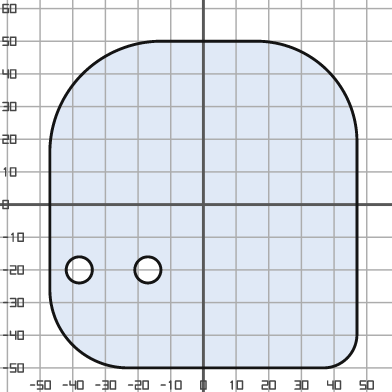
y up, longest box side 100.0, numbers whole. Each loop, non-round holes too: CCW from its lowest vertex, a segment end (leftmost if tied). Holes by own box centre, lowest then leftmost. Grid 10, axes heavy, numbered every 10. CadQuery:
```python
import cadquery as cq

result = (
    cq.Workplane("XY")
    .moveTo(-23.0, -50.0)
    .lineTo(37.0, -50.0)
    .threePointArc((44.0, -47.0), (47.0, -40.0))
    .lineTo(47.0, 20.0)
    .threePointArc((38.0, 41.0), (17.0, 50.0))
    .lineTo(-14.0, 50.0)
    .threePointArc((-37.0, 40.0), (-47.0, 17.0))
    .lineTo(-47.0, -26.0)
    .threePointArc((-40.0, -43.0), (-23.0, -50.0))
    .close()
    .moveTo(-38.0, -20.0)
    .circle(4.0)
    .moveTo(-17.0, -20.0)
    .circle(4.0)
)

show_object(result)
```